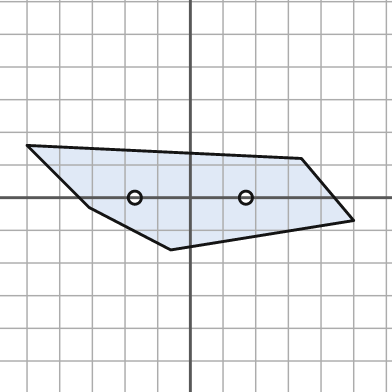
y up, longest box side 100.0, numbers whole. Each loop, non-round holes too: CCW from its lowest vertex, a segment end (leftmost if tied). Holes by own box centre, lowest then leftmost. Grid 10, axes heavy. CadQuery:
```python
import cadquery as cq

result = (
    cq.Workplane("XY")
    .moveTo(-6.0, -16.0)
    .lineTo(50.0, -7.0)
    .lineTo(34.0, 12.0)
    .lineTo(-50.0, 16.0)
    .lineTo(-31.0, -3.0)
    .close()
    .moveTo(-17.0, 0.0)
    .circle(2.0)
    .moveTo(17.0, 0.0)
    .circle(2.0)
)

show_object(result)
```